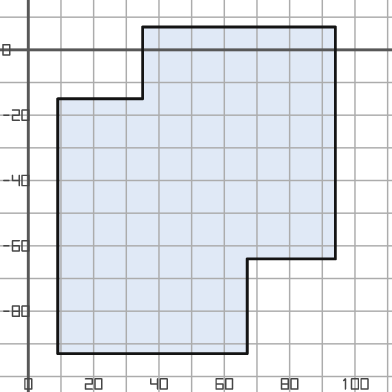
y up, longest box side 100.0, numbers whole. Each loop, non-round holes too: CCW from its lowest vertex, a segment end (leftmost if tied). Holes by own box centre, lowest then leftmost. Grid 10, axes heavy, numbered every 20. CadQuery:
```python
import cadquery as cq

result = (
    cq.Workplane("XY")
    .moveTo(9.0, -93.0)
    .lineTo(67.0, -93.0)
    .lineTo(67.0, -64.0)
    .lineTo(94.0, -64.0)
    .lineTo(94.0, 7.0)
    .lineTo(35.0, 7.0)
    .lineTo(35.0, -15.0)
    .lineTo(9.0, -15.0)
    .close()
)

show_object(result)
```